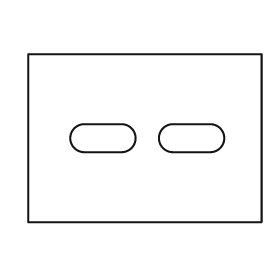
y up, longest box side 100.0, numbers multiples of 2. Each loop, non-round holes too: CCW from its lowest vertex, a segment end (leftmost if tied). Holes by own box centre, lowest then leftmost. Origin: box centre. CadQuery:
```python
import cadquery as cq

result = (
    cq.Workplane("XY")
    .moveTo(-50.0, -36.0)
    .lineTo(50.0, -36.0)
    .lineTo(50.0, 36.0)
    .lineTo(-50.0, 36.0)
    .close()
    .moveTo(-26.0, -6.0)
    .lineTo(-10.0, -6.0)
    .threePointArc((-4.0, 0.0), (-10.0, 6.0))
    .lineTo(-26.0, 6.0)
    .threePointArc((-32.0, 0.0), (-26.0, -6.0))
    .close()
    .moveTo(12.0, -6.0)
    .lineTo(28.0, -6.0)
    .threePointArc((34.0, 0.0), (28.0, 6.0))
    .lineTo(12.0, 6.0)
    .threePointArc((6.0, 0.0), (12.0, -6.0))
    .close()
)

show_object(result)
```